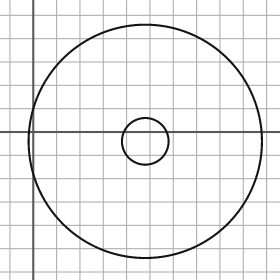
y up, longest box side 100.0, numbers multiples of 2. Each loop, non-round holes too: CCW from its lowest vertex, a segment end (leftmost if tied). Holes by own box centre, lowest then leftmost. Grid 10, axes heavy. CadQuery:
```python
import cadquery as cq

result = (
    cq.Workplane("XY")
    .moveTo(48.0, -4.0)
    .circle(50.0)
    .moveTo(48.0, -4.0)
    .circle(10.0)
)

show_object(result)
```